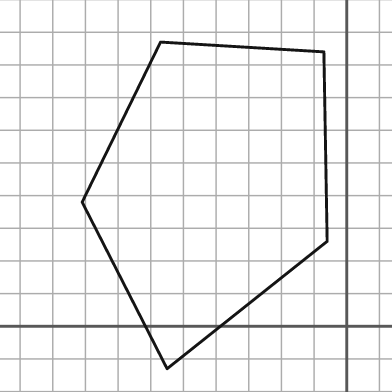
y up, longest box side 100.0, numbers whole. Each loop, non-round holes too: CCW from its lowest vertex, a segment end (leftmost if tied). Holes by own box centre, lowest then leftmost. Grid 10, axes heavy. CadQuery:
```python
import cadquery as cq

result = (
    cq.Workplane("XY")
    .moveTo(-55.0, -13.0)
    .lineTo(-6.0, 26.0)
    .lineTo(-7.0, 84.0)
    .lineTo(-57.0, 87.0)
    .lineTo(-81.0, 38.0)
    .close()
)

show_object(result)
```